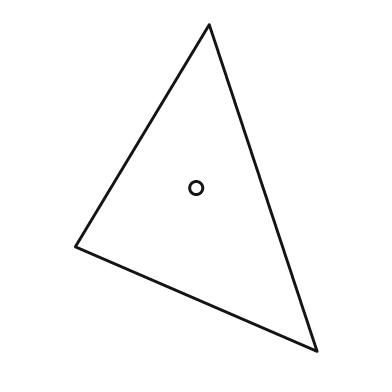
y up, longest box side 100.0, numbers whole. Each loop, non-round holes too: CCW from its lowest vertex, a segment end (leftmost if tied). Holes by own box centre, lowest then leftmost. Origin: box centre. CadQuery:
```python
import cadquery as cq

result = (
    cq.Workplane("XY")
    .moveTo(37.0, -50.0)
    .lineTo(4.0, 50.0)
    .lineTo(-37.0, -18.0)
    .close()
    .moveTo(0.0, 0.0)
    .circle(2.0)
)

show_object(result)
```